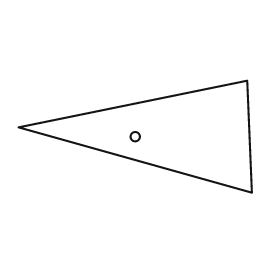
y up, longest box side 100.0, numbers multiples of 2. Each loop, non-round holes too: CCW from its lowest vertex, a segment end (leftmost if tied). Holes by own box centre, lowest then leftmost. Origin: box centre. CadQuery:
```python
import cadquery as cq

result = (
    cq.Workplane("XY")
    .moveTo(50.0, -24.0)
    .lineTo(48.0, 24.0)
    .lineTo(-50.0, 4.0)
    .close()
    .moveTo(0.0, 0.0)
    .circle(2.0)
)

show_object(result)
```